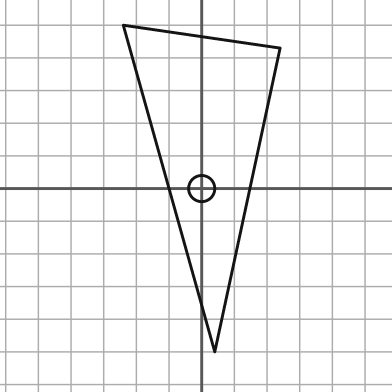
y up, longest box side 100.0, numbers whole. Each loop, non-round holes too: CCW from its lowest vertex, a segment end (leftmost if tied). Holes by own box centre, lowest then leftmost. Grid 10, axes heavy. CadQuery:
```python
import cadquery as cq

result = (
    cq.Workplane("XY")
    .moveTo(4.0, -50.0)
    .lineTo(24.0, 43.0)
    .lineTo(-24.0, 50.0)
    .close()
    .moveTo(0.0, 0.0)
    .circle(4.0)
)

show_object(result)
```